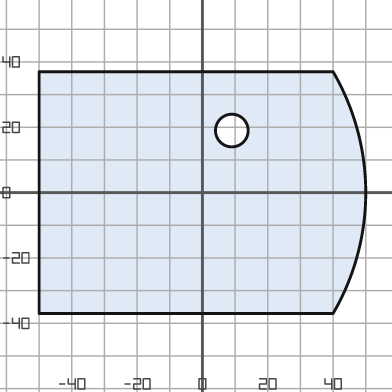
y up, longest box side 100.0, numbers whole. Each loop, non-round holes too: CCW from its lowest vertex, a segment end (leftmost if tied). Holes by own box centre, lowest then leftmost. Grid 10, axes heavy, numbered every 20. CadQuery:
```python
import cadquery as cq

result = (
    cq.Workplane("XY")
    .moveTo(-50.0, -37.0)
    .lineTo(40.0, -37.0)
    .threePointArc((50.0, 0.0), (40.0, 37.0))
    .lineTo(-50.0, 37.0)
    .close()
    .moveTo(9.0, 19.0)
    .circle(5.0)
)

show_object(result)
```